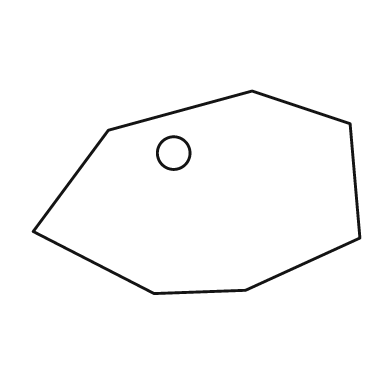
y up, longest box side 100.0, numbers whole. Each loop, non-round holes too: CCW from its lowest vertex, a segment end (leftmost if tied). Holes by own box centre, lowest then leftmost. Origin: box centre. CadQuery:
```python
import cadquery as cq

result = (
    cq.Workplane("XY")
    .moveTo(-13.0, -31.0)
    .lineTo(15.0, -30.0)
    .lineTo(50.0, -14.0)
    .lineTo(47.0, 21.0)
    .lineTo(17.0, 31.0)
    .lineTo(-27.0, 19.0)
    .lineTo(-50.0, -12.0)
    .close()
    .moveTo(-7.0, 12.0)
    .circle(5.0)
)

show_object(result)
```